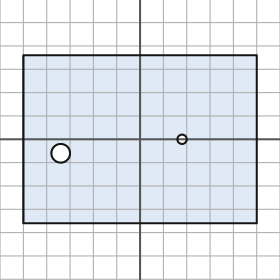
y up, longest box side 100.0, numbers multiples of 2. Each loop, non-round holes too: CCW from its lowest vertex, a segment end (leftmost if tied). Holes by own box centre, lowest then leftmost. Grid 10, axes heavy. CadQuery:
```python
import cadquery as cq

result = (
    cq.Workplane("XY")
    .moveTo(-50.0, -36.0)
    .lineTo(50.0, -36.0)
    .lineTo(50.0, 36.0)
    .lineTo(-50.0, 36.0)
    .close()
    .moveTo(-34.0, -6.0)
    .circle(4.0)
    .moveTo(18.0, 0.0)
    .circle(2.0)
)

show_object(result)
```